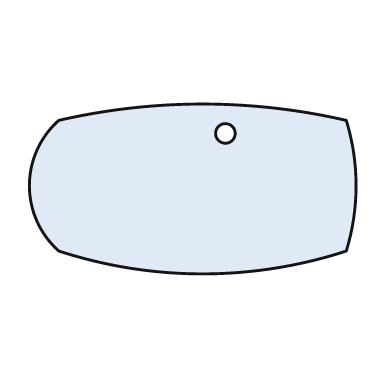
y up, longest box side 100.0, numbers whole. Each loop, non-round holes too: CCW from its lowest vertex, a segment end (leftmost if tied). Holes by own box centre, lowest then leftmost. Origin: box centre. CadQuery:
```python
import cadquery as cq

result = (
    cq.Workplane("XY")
    .moveTo(-41.0, -19.0)
    .threePointArc((3.0, -26.0), (47.0, -19.0))
    .threePointArc((50.0, 1.0), (47.0, 21.0))
    .threePointArc((3.0, 26.0), (-41.0, 21.0))
    .threePointArc((-50.0, 1.0), (-41.0, -19.0))
    .close()
    .moveTo(10.0, 17.0)
    .circle(3.0)
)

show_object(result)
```